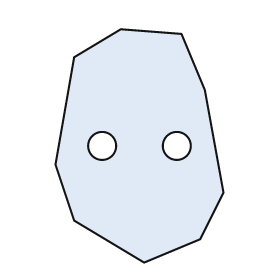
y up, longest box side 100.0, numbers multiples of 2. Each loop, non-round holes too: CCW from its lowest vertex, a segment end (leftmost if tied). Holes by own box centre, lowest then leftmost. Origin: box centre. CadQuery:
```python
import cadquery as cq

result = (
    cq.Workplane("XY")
    .moveTo(2.0, -50.0)
    .lineTo(26.0, -40.0)
    .lineTo(36.0, -20.0)
    .lineTo(28.0, 24.0)
    .lineTo(18.0, 48.0)
    .lineTo(-8.0, 50.0)
    .lineTo(-28.0, 38.0)
    .lineTo(-36.0, -8.0)
    .lineTo(-28.0, -32.0)
    .close()
    .moveTo(-16.0, 0.0)
    .circle(6.0)
    .moveTo(16.0, 0.0)
    .circle(6.0)
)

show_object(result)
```